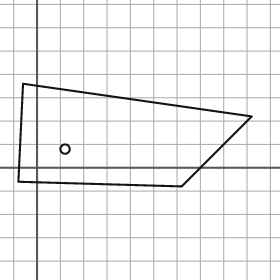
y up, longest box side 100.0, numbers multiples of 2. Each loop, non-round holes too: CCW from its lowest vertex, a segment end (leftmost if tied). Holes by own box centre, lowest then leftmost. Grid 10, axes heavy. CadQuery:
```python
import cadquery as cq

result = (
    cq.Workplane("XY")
    .moveTo(62.0, -8.0)
    .lineTo(92.0, 22.0)
    .lineTo(-6.0, 36.0)
    .lineTo(-8.0, -6.0)
    .close()
    .moveTo(12.0, 8.0)
    .circle(2.0)
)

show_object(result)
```